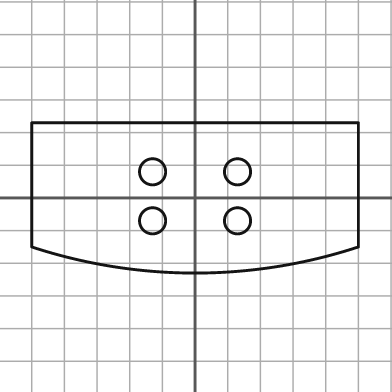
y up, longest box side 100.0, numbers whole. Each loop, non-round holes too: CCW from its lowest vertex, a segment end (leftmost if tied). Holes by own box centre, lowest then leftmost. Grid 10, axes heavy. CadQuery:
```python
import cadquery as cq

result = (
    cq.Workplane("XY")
    .moveTo(-50.0, -15.0)
    .threePointArc((0.0, -23.0), (50.0, -15.0))
    .lineTo(50.0, 23.0)
    .lineTo(-50.0, 23.0)
    .close()
    .moveTo(-13.0, -7.0)
    .circle(4.0)
    .moveTo(13.0, -7.0)
    .circle(4.0)
    .moveTo(-13.0, 8.0)
    .circle(4.0)
    .moveTo(13.0, 8.0)
    .circle(4.0)
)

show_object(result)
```